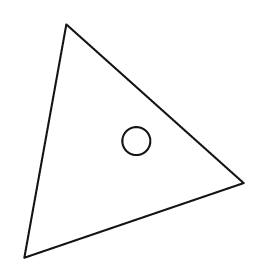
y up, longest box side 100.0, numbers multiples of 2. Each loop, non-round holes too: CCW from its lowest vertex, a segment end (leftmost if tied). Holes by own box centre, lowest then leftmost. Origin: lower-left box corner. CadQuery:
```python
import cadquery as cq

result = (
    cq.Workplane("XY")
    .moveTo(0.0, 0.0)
    .lineTo(94.0, 32.0)
    .lineTo(18.0, 100.0)
    .close()
    .moveTo(48.0, 50.0)
    .circle(6.0)
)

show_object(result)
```